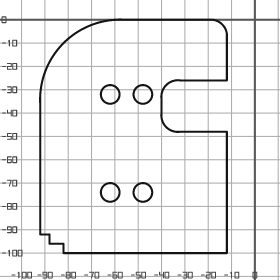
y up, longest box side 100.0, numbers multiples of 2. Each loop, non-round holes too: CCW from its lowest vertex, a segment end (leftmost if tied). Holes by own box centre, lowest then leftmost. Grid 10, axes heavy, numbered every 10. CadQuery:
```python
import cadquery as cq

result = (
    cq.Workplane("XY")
    .moveTo(-82.0, -100.0)
    .lineTo(-12.0, -100.0)
    .lineTo(-12.0, -48.0)
    .lineTo(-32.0, -48.0)
    .threePointArc((-38.0, -46.0), (-40.0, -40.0))
    .lineTo(-40.0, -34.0)
    .threePointArc((-38.0, -28.0), (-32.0, -26.0))
    .lineTo(-12.0, -26.0)
    .lineTo(-12.0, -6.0)
    .threePointArc((-14.0, -2.0), (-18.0, 0.0))
    .lineTo(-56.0, 0.0)
    .threePointArc((-82.0, -10.0), (-92.0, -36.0))
    .lineTo(-92.0, -92.0)
    .lineTo(-88.0, -92.0)
    .lineTo(-88.0, -96.0)
    .lineTo(-82.0, -96.0)
    .close()
    .moveTo(-62.0, -74.0)
    .circle(4.0)
    .moveTo(-48.0, -74.0)
    .circle(4.0)
    .moveTo(-62.0, -32.0)
    .circle(4.0)
    .moveTo(-48.0, -32.0)
    .circle(4.0)
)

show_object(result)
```